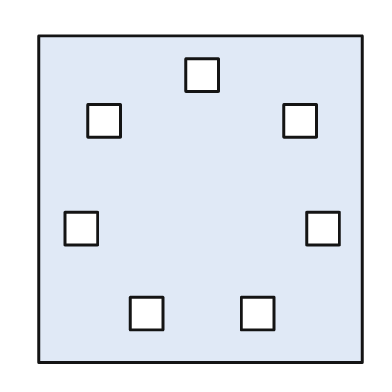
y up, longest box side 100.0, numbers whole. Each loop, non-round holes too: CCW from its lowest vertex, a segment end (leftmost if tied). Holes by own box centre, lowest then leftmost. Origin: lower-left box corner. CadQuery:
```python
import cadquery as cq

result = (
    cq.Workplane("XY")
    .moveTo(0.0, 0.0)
    .lineTo(99.0, 0.0)
    .lineTo(99.0, 100.0)
    .lineTo(0.0, 100.0)
    .close()
    .moveTo(28.0, 10.0)
    .lineTo(38.0, 10.0)
    .lineTo(38.0, 20.0)
    .lineTo(28.0, 20.0)
    .close()
    .moveTo(62.0, 10.0)
    .lineTo(72.0, 10.0)
    .lineTo(72.0, 20.0)
    .lineTo(62.0, 20.0)
    .close()
    .moveTo(8.0, 36.0)
    .lineTo(18.0, 36.0)
    .lineTo(18.0, 46.0)
    .lineTo(8.0, 46.0)
    .close()
    .moveTo(82.0, 36.0)
    .lineTo(92.0, 36.0)
    .lineTo(92.0, 46.0)
    .lineTo(82.0, 46.0)
    .close()
    .moveTo(15.0, 69.0)
    .lineTo(25.0, 69.0)
    .lineTo(25.0, 79.0)
    .lineTo(15.0, 79.0)
    .close()
    .moveTo(75.0, 69.0)
    .lineTo(85.0, 69.0)
    .lineTo(85.0, 79.0)
    .lineTo(75.0, 79.0)
    .close()
    .moveTo(45.0, 83.0)
    .lineTo(55.0, 83.0)
    .lineTo(55.0, 93.0)
    .lineTo(45.0, 93.0)
    .close()
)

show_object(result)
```